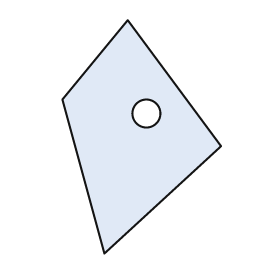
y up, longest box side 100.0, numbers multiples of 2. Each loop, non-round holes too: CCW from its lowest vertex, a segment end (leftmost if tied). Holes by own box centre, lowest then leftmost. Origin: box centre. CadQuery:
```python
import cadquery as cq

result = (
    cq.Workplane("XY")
    .moveTo(-16.0, -50.0)
    .lineTo(34.0, -4.0)
    .lineTo(-6.0, 50.0)
    .lineTo(-34.0, 16.0)
    .close()
    .moveTo(2.0, 10.0)
    .circle(6.0)
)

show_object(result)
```